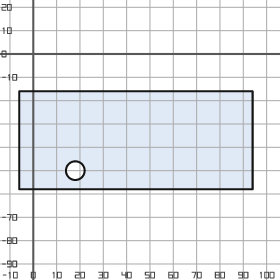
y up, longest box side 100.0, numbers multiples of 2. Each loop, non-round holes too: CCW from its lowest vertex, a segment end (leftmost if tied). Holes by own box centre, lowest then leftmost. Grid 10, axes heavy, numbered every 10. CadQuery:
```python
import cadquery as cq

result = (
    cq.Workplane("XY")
    .moveTo(-6.0, -58.0)
    .lineTo(94.0, -58.0)
    .lineTo(94.0, -16.0)
    .lineTo(-6.0, -16.0)
    .close()
    .moveTo(18.0, -50.0)
    .circle(4.0)
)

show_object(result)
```